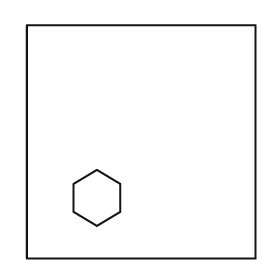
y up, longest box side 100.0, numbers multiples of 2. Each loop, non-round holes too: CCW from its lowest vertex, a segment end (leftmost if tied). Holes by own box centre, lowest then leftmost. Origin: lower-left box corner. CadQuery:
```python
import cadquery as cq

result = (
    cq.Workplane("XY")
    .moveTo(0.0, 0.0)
    .lineTo(98.0, 0.0)
    .lineTo(98.0, 100.0)
    .lineTo(0.0, 100.0)
    .close()
    .moveTo(30.0, 14.0)
    .lineTo(40.0, 20.0)
    .lineTo(40.0, 32.0)
    .lineTo(30.0, 38.0)
    .lineTo(20.0, 32.0)
    .lineTo(20.0, 20.0)
    .close()
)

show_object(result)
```